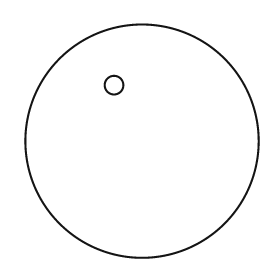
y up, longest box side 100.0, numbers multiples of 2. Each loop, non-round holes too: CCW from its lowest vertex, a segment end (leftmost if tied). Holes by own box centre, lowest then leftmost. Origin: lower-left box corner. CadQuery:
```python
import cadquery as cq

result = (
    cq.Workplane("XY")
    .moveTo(50.0, 50.0)
    .circle(50.0)
    .moveTo(38.0, 74.0)
    .circle(4.0)
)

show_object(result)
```